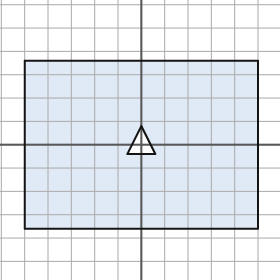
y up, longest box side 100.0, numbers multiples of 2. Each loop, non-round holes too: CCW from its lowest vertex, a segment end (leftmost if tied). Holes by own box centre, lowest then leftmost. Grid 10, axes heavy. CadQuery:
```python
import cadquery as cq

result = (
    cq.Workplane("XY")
    .moveTo(-50.0, -36.0)
    .lineTo(50.0, -36.0)
    .lineTo(50.0, 36.0)
    .lineTo(-50.0, 36.0)
    .close()
    .moveTo(-6.0, -4.0)
    .lineTo(6.0, -4.0)
    .lineTo(0.0, 8.0)
    .close()
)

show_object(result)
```